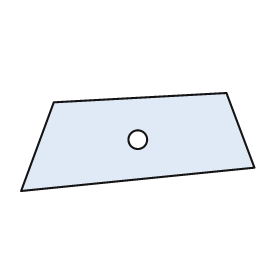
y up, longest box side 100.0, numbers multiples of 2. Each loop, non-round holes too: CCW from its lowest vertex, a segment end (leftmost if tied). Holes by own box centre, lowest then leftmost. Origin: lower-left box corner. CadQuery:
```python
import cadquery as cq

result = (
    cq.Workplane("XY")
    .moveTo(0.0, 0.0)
    .lineTo(100.0, 10.0)
    .lineTo(88.0, 42.0)
    .lineTo(14.0, 38.0)
    .close()
    .moveTo(50.0, 22.0)
    .circle(4.0)
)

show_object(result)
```